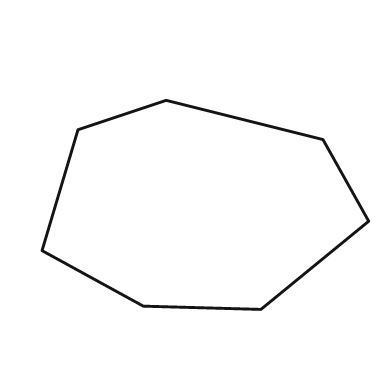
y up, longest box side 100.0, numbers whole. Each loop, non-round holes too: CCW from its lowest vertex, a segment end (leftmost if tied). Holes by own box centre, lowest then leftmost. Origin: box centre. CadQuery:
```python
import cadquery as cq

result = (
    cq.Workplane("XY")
    .moveTo(17.0, -32.0)
    .lineTo(50.0, -5.0)
    .lineTo(36.0, 20.0)
    .lineTo(-12.0, 32.0)
    .lineTo(-39.0, 23.0)
    .lineTo(-50.0, -14.0)
    .lineTo(-19.0, -31.0)
    .close()
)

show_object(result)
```